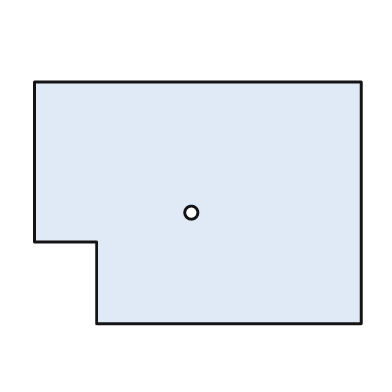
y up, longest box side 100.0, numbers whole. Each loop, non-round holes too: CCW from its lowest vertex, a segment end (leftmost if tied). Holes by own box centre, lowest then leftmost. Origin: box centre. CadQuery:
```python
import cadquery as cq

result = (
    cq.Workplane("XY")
    .moveTo(-31.0, -37.0)
    .lineTo(50.0, -37.0)
    .lineTo(50.0, 37.0)
    .lineTo(-50.0, 37.0)
    .lineTo(-50.0, -12.0)
    .lineTo(-31.0, -12.0)
    .close()
    .moveTo(-2.0, -3.0)
    .circle(2.0)
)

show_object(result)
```